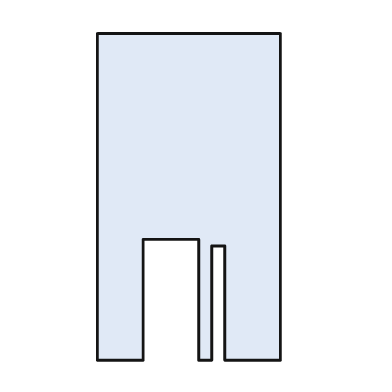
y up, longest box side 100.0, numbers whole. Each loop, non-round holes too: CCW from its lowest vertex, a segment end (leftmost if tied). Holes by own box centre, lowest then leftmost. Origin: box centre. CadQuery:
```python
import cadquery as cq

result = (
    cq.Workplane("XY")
    .moveTo(-28.0, -50.0)
    .lineTo(-14.0, -50.0)
    .lineTo(-14.0, -13.0)
    .lineTo(3.0, -13.0)
    .lineTo(3.0, -50.0)
    .lineTo(7.0, -50.0)
    .lineTo(7.0, -15.0)
    .lineTo(11.0, -15.0)
    .lineTo(11.0, -50.0)
    .lineTo(28.0, -50.0)
    .lineTo(28.0, 50.0)
    .lineTo(-28.0, 50.0)
    .close()
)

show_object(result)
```